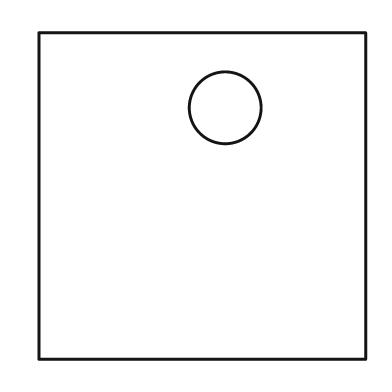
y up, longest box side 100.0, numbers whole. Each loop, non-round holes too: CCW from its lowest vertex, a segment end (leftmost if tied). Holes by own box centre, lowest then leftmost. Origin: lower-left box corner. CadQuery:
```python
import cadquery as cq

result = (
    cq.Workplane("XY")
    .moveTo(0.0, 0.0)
    .lineTo(100.0, 0.0)
    .lineTo(100.0, 100.0)
    .lineTo(0.0, 100.0)
    .close()
    .moveTo(57.0, 77.0)
    .circle(11.0)
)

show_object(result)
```